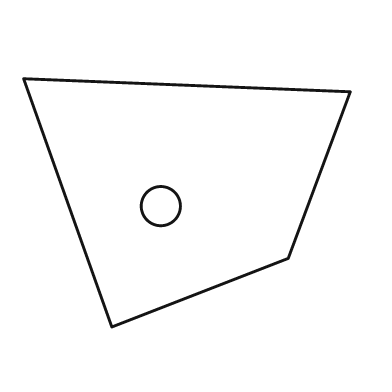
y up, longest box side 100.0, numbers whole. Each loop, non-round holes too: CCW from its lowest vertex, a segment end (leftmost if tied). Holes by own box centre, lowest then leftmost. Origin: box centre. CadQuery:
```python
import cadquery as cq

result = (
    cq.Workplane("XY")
    .moveTo(-23.0, -38.0)
    .lineTo(31.0, -17.0)
    .lineTo(50.0, 34.0)
    .lineTo(-50.0, 38.0)
    .close()
    .moveTo(-8.0, -1.0)
    .circle(6.0)
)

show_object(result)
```